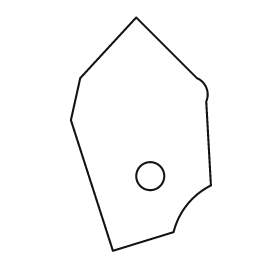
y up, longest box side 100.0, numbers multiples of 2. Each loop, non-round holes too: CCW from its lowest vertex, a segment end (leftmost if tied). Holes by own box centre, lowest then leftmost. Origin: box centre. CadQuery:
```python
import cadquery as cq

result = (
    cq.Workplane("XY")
    .moveTo(-12.0, -50.0)
    .lineTo(14.0, -42.0)
    .threePointArc((20.0, -30.0), (30.0, -22.0))
    .lineTo(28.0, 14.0)
    .threePointArc((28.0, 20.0), (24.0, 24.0))
    .lineTo(-2.0, 50.0)
    .lineTo(-26.0, 24.0)
    .lineTo(-30.0, 6.0)
    .close()
    .moveTo(4.0, -18.0)
    .circle(6.0)
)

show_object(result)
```